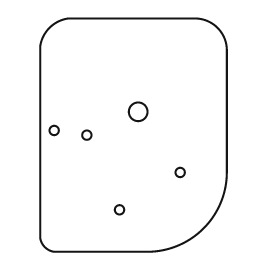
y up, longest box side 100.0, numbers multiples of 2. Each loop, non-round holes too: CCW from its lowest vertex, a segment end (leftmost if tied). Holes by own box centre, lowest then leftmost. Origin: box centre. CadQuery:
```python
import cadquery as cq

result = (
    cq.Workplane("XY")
    .moveTo(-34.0, -50.0)
    .lineTo(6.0, -50.0)
    .threePointArc((30.0, -40.0), (40.0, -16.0))
    .lineTo(40.0, 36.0)
    .threePointArc((36.0, 46.0), (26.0, 50.0))
    .lineTo(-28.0, 50.0)
    .threePointArc((-36.0, 46.0), (-40.0, 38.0))
    .lineTo(-40.0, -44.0)
    .threePointArc((-38.0, -48.0), (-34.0, -50.0))
    .close()
    .moveTo(-6.0, -32.0)
    .circle(2.0)
    .moveTo(20.0, -16.0)
    .circle(2.0)
    .moveTo(-20.0, 0.0)
    .circle(2.0)
    .moveTo(-34.0, 2.0)
    .circle(2.0)
    .moveTo(2.0, 10.0)
    .circle(4.0)
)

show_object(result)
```